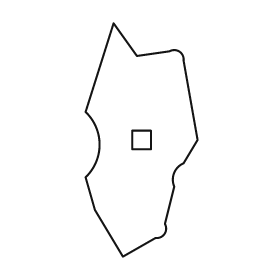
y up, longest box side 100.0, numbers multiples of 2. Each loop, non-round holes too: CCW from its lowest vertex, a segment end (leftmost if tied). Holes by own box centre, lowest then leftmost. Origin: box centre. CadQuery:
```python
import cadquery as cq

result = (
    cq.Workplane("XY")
    .moveTo(-8.0, -50.0)
    .lineTo(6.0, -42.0)
    .threePointArc((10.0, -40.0), (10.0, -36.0))
    .lineTo(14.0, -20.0)
    .threePointArc((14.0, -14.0), (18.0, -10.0))
    .lineTo(24.0, 0.0)
    .lineTo(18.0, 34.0)
    .threePointArc((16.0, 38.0), (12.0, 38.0))
    .lineTo(-2.0, 36.0)
    .lineTo(-12.0, 50.0)
    .lineTo(-24.0, 12.0)
    .threePointArc((-18.0, -2.0), (-24.0, -16.0))
    .lineTo(-20.0, -30.0)
    .close()
    .moveTo(-4.0, -4.0)
    .lineTo(4.0, -4.0)
    .lineTo(4.0, 4.0)
    .lineTo(-4.0, 4.0)
    .close()
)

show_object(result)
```